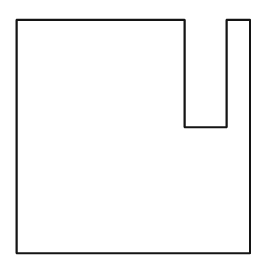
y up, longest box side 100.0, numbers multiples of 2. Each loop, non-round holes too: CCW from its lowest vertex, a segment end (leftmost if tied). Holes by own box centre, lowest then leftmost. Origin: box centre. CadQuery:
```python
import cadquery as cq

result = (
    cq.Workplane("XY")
    .moveTo(-50.0, -50.0)
    .lineTo(50.0, -50.0)
    .lineTo(50.0, 50.0)
    .lineTo(40.0, 50.0)
    .lineTo(40.0, 4.0)
    .lineTo(22.0, 4.0)
    .lineTo(22.0, 50.0)
    .lineTo(-50.0, 50.0)
    .close()
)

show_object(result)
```